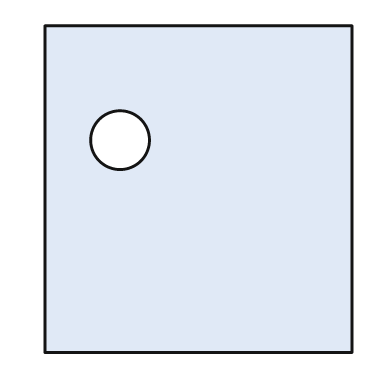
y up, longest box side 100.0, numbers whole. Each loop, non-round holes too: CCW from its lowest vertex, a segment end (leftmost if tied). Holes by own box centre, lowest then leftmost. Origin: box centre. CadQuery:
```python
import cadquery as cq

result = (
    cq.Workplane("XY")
    .moveTo(-47.0, -50.0)
    .lineTo(47.0, -50.0)
    .lineTo(47.0, 50.0)
    .lineTo(-47.0, 50.0)
    .close()
    .moveTo(-24.0, 15.0)
    .circle(9.0)
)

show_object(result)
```